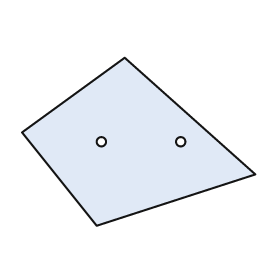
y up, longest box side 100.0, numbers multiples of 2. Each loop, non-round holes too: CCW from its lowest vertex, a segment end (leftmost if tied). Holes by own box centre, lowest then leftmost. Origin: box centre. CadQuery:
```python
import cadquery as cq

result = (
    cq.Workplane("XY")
    .moveTo(-18.0, -36.0)
    .lineTo(50.0, -14.0)
    .lineTo(-6.0, 36.0)
    .lineTo(-50.0, 4.0)
    .close()
    .moveTo(-16.0, 0.0)
    .circle(2.0)
    .moveTo(18.0, 0.0)
    .circle(2.0)
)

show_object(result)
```